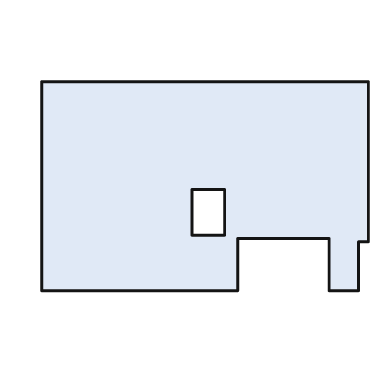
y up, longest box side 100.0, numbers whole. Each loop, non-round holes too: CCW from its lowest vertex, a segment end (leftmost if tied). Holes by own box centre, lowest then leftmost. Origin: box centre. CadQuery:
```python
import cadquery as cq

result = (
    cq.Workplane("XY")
    .moveTo(-50.0, -32.0)
    .lineTo(10.0, -32.0)
    .lineTo(10.0, -16.0)
    .lineTo(38.0, -16.0)
    .lineTo(38.0, -32.0)
    .lineTo(47.0, -32.0)
    .lineTo(47.0, -17.0)
    .lineTo(50.0, -17.0)
    .lineTo(50.0, 32.0)
    .lineTo(-50.0, 32.0)
    .close()
    .moveTo(-4.0, -15.0)
    .lineTo(6.0, -15.0)
    .lineTo(6.0, -1.0)
    .lineTo(-4.0, -1.0)
    .close()
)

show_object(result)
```